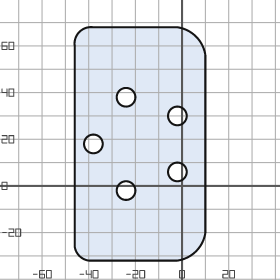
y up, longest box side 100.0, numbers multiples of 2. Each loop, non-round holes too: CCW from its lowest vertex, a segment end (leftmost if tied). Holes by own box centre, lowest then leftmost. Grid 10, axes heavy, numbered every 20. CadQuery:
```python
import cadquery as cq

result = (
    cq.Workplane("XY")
    .moveTo(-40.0, -32.0)
    .lineTo(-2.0, -32.0)
    .threePointArc((6.0, -28.0), (10.0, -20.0))
    .lineTo(10.0, 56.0)
    .threePointArc((6.0, 64.0), (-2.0, 68.0))
    .lineTo(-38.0, 68.0)
    .threePointArc((-44.0, 66.0), (-46.0, 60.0))
    .lineTo(-46.0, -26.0)
    .threePointArc((-44.0, -30.0), (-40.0, -32.0))
    .close()
    .moveTo(-24.0, -2.0)
    .circle(4.0)
    .moveTo(-2.0, 6.0)
    .circle(4.0)
    .moveTo(-38.0, 18.0)
    .circle(4.0)
    .moveTo(-2.0, 30.0)
    .circle(4.0)
    .moveTo(-24.0, 38.0)
    .circle(4.0)
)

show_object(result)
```